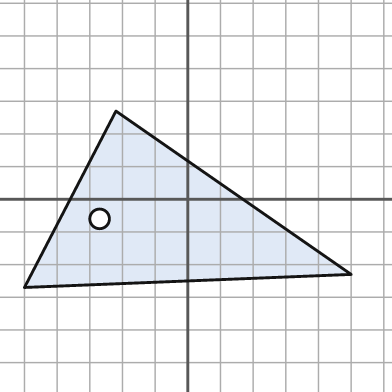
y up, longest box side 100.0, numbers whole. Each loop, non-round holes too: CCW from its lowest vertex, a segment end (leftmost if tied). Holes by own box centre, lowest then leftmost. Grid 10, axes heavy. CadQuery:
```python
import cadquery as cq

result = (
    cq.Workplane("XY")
    .moveTo(-50.0, -27.0)
    .lineTo(50.0, -23.0)
    .lineTo(-22.0, 27.0)
    .close()
    .moveTo(-27.0, -6.0)
    .circle(3.0)
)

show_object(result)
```